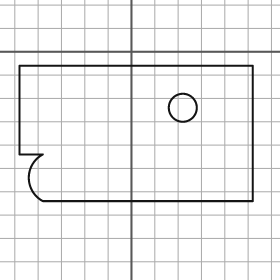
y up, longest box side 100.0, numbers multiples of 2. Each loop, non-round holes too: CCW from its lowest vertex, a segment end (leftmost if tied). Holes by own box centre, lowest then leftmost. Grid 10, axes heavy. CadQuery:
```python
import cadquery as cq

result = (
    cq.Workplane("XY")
    .moveTo(-38.0, -64.0)
    .lineTo(52.0, -64.0)
    .lineTo(52.0, -6.0)
    .lineTo(-48.0, -6.0)
    .lineTo(-48.0, -44.0)
    .lineTo(-38.0, -44.0)
    .threePointArc((-44.0, -54.0), (-38.0, -64.0))
    .close()
    .moveTo(22.0, -24.0)
    .circle(6.0)
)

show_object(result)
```